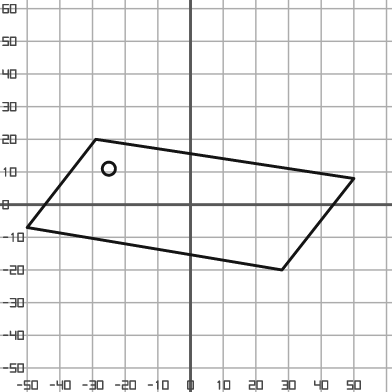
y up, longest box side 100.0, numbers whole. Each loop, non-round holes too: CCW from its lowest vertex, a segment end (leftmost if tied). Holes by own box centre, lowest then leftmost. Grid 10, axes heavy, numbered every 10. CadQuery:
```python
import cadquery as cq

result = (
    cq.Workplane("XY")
    .moveTo(28.0, -20.0)
    .lineTo(50.0, 8.0)
    .lineTo(-29.0, 20.0)
    .lineTo(-50.0, -7.0)
    .close()
    .moveTo(-25.0, 11.0)
    .circle(2.0)
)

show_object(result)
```